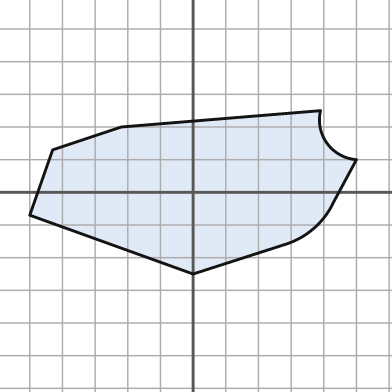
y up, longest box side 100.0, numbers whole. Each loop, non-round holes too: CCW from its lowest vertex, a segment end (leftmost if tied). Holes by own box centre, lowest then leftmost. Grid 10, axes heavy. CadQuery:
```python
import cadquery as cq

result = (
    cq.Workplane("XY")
    .moveTo(0.0, -25.0)
    .lineTo(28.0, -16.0)
    .threePointArc((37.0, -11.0), (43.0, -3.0))
    .lineTo(50.0, 10.0)
    .threePointArc((41.0, 15.0), (39.0, 25.0))
    .lineTo(-22.0, 20.0)
    .lineTo(-43.0, 13.0)
    .lineTo(-50.0, -7.0)
    .close()
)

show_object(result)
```